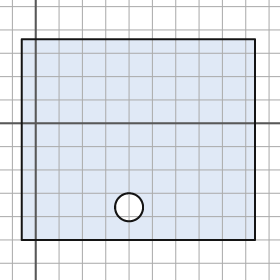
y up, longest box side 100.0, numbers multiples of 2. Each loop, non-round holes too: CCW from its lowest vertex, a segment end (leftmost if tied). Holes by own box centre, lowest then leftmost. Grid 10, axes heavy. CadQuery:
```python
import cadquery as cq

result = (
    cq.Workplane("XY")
    .moveTo(-6.0, -50.0)
    .lineTo(94.0, -50.0)
    .lineTo(94.0, 36.0)
    .lineTo(-6.0, 36.0)
    .close()
    .moveTo(40.0, -36.0)
    .circle(6.0)
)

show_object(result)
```